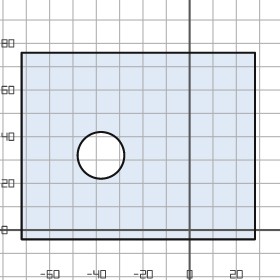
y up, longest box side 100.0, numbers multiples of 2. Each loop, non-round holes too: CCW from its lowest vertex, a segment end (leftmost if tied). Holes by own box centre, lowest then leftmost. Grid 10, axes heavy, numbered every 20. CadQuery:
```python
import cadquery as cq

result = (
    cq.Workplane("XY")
    .moveTo(-72.0, -4.0)
    .lineTo(28.0, -4.0)
    .lineTo(28.0, 76.0)
    .lineTo(-72.0, 76.0)
    .close()
    .moveTo(-38.0, 32.0)
    .circle(10.0)
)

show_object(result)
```